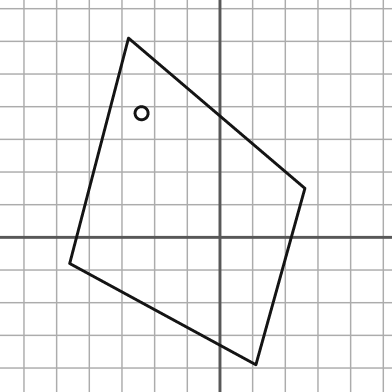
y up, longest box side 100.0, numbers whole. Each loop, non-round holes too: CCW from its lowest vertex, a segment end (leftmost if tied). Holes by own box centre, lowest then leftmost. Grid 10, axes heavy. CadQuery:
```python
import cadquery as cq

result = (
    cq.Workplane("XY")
    .moveTo(11.0, -39.0)
    .lineTo(26.0, 15.0)
    .lineTo(-28.0, 61.0)
    .lineTo(-46.0, -8.0)
    .close()
    .moveTo(-24.0, 38.0)
    .circle(2.0)
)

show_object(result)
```